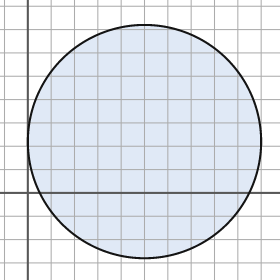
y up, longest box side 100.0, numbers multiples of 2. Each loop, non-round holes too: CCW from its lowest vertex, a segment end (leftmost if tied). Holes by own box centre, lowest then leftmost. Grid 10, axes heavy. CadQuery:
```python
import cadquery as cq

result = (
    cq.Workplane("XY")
    .moveTo(50.0, 22.0)
    .circle(50.0)
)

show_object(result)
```